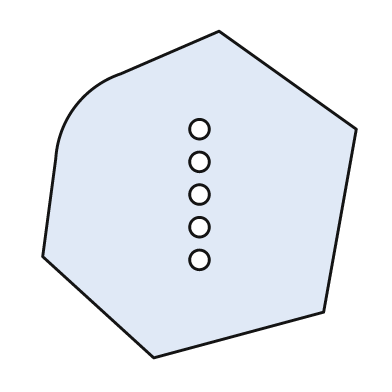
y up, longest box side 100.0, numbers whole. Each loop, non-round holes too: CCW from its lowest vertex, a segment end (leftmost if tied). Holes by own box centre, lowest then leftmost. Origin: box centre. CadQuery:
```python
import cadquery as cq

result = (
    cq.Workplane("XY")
    .moveTo(-14.0, -50.0)
    .lineTo(38.0, -36.0)
    .lineTo(48.0, 20.0)
    .lineTo(6.0, 50.0)
    .lineTo(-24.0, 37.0)
    .threePointArc((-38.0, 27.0), (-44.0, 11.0))
    .lineTo(-48.0, -19.0)
    .close()
    .moveTo(0.0, -20.0)
    .circle(3.0)
    .moveTo(0.0, -10.0)
    .circle(3.0)
    .moveTo(0.0, 0.0)
    .circle(3.0)
    .moveTo(0.0, 10.0)
    .circle(3.0)
    .moveTo(0.0, 20.0)
    .circle(3.0)
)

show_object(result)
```